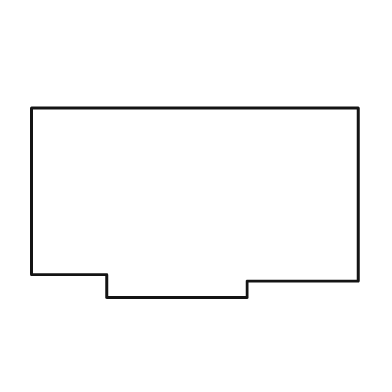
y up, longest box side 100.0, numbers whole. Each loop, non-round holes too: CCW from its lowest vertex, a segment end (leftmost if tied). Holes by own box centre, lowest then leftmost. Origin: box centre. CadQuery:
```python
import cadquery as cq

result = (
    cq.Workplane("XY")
    .moveTo(-27.0, -29.0)
    .lineTo(16.0, -29.0)
    .lineTo(16.0, -24.0)
    .lineTo(50.0, -24.0)
    .lineTo(50.0, 29.0)
    .lineTo(-50.0, 29.0)
    .lineTo(-50.0, -22.0)
    .lineTo(-27.0, -22.0)
    .close()
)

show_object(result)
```